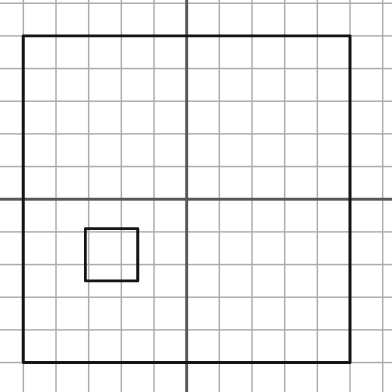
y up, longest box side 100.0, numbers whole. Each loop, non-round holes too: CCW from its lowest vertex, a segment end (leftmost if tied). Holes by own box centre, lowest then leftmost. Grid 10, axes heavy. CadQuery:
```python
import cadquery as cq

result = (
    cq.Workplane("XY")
    .moveTo(-50.0, -50.0)
    .lineTo(50.0, -50.0)
    .lineTo(50.0, 50.0)
    .lineTo(-50.0, 50.0)
    .close()
    .moveTo(-31.0, -25.0)
    .lineTo(-15.0, -25.0)
    .lineTo(-15.0, -9.0)
    .lineTo(-31.0, -9.0)
    .close()
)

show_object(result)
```